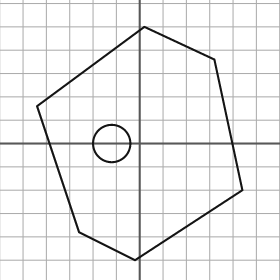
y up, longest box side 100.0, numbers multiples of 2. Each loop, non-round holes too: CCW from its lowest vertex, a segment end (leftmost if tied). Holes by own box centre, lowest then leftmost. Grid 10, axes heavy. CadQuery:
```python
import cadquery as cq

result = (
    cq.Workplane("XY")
    .moveTo(-2.0, -50.0)
    .lineTo(44.0, -20.0)
    .lineTo(32.0, 36.0)
    .lineTo(2.0, 50.0)
    .lineTo(-44.0, 16.0)
    .lineTo(-26.0, -38.0)
    .close()
    .moveTo(-12.0, 0.0)
    .circle(8.0)
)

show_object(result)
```